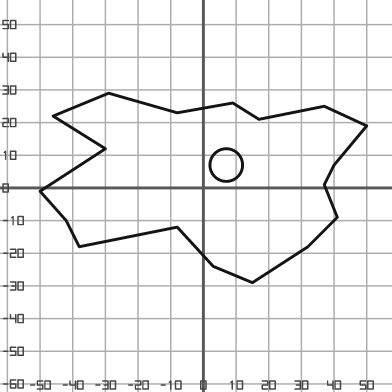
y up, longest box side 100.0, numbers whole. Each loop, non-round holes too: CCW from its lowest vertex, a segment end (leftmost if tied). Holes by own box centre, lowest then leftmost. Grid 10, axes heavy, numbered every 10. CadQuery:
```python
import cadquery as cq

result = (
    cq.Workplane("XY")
    .moveTo(15.0, -29.0)
    .lineTo(32.0, -18.0)
    .lineTo(41.0, -9.0)
    .lineTo(37.0, 1.0)
    .lineTo(40.0, 7.0)
    .lineTo(50.0, 19.0)
    .lineTo(37.0, 25.0)
    .lineTo(17.0, 21.0)
    .lineTo(9.0, 26.0)
    .lineTo(-8.0, 23.0)
    .lineTo(-29.0, 29.0)
    .lineTo(-46.0, 22.0)
    .lineTo(-30.0, 12.0)
    .lineTo(-50.0, -1.0)
    .lineTo(-42.0, -10.0)
    .lineTo(-38.0, -18.0)
    .lineTo(-8.0, -12.0)
    .lineTo(3.0, -24.0)
    .close()
    .moveTo(7.0, 7.0)
    .circle(5.0)
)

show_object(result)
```